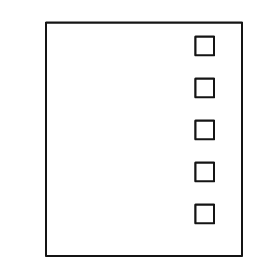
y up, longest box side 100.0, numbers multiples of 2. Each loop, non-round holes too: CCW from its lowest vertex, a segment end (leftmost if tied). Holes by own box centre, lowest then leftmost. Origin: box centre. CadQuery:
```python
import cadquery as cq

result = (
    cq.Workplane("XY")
    .moveTo(-42.0, -50.0)
    .lineTo(42.0, -50.0)
    .lineTo(42.0, 50.0)
    .lineTo(-42.0, 50.0)
    .close()
    .moveTo(22.0, -36.0)
    .lineTo(30.0, -36.0)
    .lineTo(30.0, -28.0)
    .lineTo(22.0, -28.0)
    .close()
    .moveTo(22.0, -18.0)
    .lineTo(30.0, -18.0)
    .lineTo(30.0, -10.0)
    .lineTo(22.0, -10.0)
    .close()
    .moveTo(22.0, 0.0)
    .lineTo(30.0, 0.0)
    .lineTo(30.0, 8.0)
    .lineTo(22.0, 8.0)
    .close()
    .moveTo(22.0, 18.0)
    .lineTo(30.0, 18.0)
    .lineTo(30.0, 26.0)
    .lineTo(22.0, 26.0)
    .close()
    .moveTo(22.0, 36.0)
    .lineTo(30.0, 36.0)
    .lineTo(30.0, 44.0)
    .lineTo(22.0, 44.0)
    .close()
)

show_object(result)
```